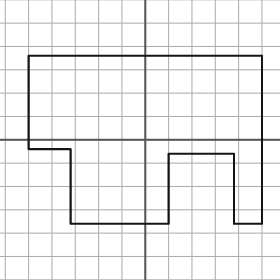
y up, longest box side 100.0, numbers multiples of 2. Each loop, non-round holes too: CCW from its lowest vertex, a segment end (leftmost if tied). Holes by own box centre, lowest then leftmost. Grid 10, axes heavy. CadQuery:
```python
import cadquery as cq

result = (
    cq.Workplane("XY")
    .moveTo(-32.0, -36.0)
    .lineTo(10.0, -36.0)
    .lineTo(10.0, -6.0)
    .lineTo(38.0, -6.0)
    .lineTo(38.0, -36.0)
    .lineTo(50.0, -36.0)
    .lineTo(50.0, 36.0)
    .lineTo(-50.0, 36.0)
    .lineTo(-50.0, -4.0)
    .lineTo(-32.0, -4.0)
    .close()
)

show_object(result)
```